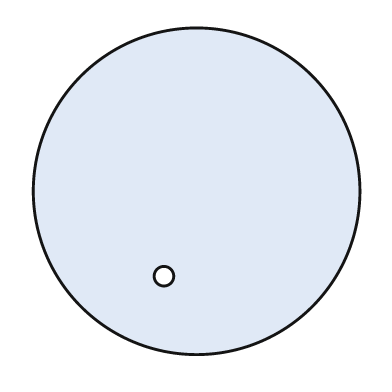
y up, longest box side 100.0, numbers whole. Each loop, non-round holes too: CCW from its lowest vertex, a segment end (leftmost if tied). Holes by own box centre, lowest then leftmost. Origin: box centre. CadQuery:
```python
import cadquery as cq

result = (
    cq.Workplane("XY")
    .moveTo(0.0, 0.0)
    .circle(50.0)
    .moveTo(-10.0, -26.0)
    .circle(3.0)
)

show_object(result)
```